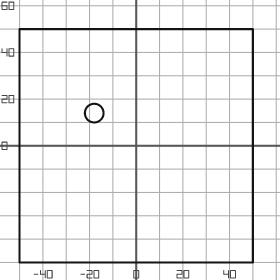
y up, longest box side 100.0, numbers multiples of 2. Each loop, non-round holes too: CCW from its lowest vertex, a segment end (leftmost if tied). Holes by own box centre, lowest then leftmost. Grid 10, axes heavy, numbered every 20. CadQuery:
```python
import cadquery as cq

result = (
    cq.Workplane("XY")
    .moveTo(-50.0, -50.0)
    .lineTo(50.0, -50.0)
    .lineTo(50.0, 50.0)
    .lineTo(-50.0, 50.0)
    .close()
    .moveTo(-18.0, 14.0)
    .circle(4.0)
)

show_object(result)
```